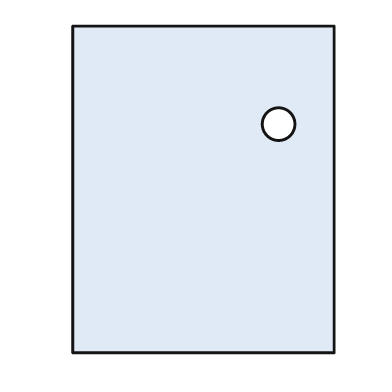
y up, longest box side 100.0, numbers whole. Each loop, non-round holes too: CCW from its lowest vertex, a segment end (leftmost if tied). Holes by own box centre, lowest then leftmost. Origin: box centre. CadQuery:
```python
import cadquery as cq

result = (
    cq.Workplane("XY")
    .moveTo(-40.0, -50.0)
    .lineTo(40.0, -50.0)
    .lineTo(40.0, 50.0)
    .lineTo(-40.0, 50.0)
    .close()
    .moveTo(23.0, 20.0)
    .circle(5.0)
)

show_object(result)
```